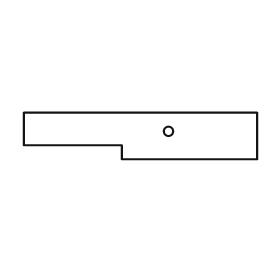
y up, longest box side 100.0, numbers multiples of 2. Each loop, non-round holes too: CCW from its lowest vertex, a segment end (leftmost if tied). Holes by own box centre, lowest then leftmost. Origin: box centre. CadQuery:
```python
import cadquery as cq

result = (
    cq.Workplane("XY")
    .moveTo(-8.0, -10.0)
    .lineTo(50.0, -10.0)
    .lineTo(50.0, 10.0)
    .lineTo(-50.0, 10.0)
    .lineTo(-50.0, -4.0)
    .lineTo(-8.0, -4.0)
    .close()
    .moveTo(12.0, 2.0)
    .circle(2.0)
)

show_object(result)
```